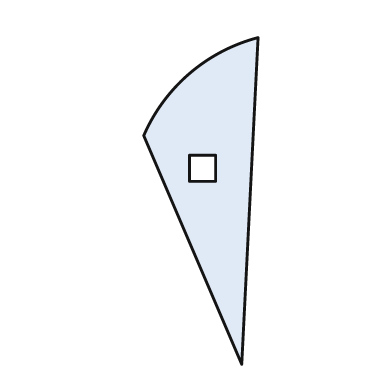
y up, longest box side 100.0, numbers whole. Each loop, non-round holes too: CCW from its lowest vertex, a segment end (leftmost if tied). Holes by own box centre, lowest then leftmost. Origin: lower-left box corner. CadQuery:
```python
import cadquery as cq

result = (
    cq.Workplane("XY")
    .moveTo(30.0, 0.0)
    .lineTo(35.0, 100.0)
    .threePointArc((14.0, 89.0), (0.0, 70.0))
    .close()
    .moveTo(14.0, 56.0)
    .lineTo(22.0, 56.0)
    .lineTo(22.0, 64.0)
    .lineTo(14.0, 64.0)
    .close()
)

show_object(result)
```